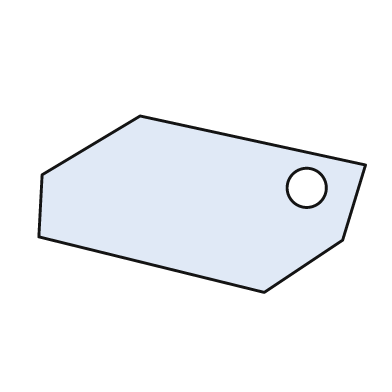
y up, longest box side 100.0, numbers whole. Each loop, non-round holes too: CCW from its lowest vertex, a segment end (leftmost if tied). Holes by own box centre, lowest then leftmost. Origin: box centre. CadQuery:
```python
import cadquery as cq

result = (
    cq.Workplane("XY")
    .moveTo(19.0, -27.0)
    .lineTo(43.0, -11.0)
    .lineTo(50.0, 12.0)
    .lineTo(-19.0, 27.0)
    .lineTo(-49.0, 9.0)
    .lineTo(-50.0, -10.0)
    .close()
    .moveTo(32.0, 5.0)
    .circle(6.0)
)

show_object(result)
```